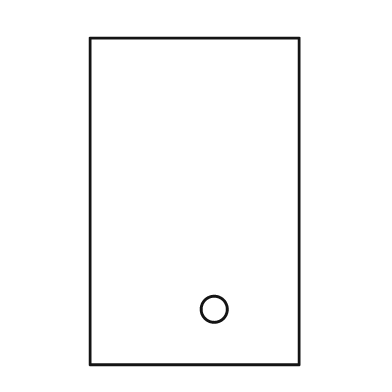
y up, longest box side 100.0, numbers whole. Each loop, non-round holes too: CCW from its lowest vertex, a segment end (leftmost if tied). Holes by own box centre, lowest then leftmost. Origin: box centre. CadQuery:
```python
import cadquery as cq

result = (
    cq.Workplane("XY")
    .moveTo(-32.0, -50.0)
    .lineTo(32.0, -50.0)
    .lineTo(32.0, 50.0)
    .lineTo(-32.0, 50.0)
    .close()
    .moveTo(6.0, -33.0)
    .circle(4.0)
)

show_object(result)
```